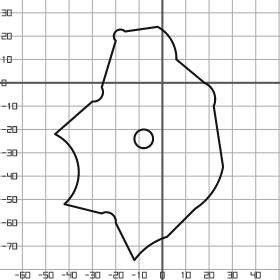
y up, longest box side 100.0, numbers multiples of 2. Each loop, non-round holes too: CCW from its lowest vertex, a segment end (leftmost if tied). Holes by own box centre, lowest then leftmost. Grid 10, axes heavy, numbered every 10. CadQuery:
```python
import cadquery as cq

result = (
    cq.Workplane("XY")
    .moveTo(-12.0, -76.0)
    .threePointArc((-6.0, -70.0), (2.0, -66.0))
    .lineTo(14.0, -54.0)
    .threePointArc((22.0, -46.0), (26.0, -36.0))
    .lineTo(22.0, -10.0)
    .threePointArc((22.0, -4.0), (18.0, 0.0))
    .lineTo(6.0, 10.0)
    .threePointArc((4.0, 18.0), (-2.0, 24.0))
    .lineTo(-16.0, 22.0)
    .threePointArc((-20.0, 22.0), (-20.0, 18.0))
    .lineTo(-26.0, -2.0)
    .threePointArc((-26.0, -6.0), (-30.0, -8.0))
    .lineTo(-46.0, -22.0)
    .threePointArc((-36.0, -36.0), (-42.0, -52.0))
    .lineTo(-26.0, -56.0)
    .threePointArc((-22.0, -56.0), (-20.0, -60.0))
    .close()
    .moveTo(-8.0, -24.0)
    .circle(4.0)
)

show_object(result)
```